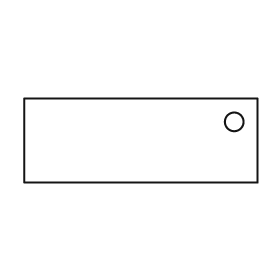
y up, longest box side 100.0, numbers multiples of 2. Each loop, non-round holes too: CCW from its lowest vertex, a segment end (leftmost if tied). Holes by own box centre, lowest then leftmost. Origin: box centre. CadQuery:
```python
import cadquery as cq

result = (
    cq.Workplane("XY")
    .moveTo(-50.0, -18.0)
    .lineTo(50.0, -18.0)
    .lineTo(50.0, 18.0)
    .lineTo(-50.0, 18.0)
    .close()
    .moveTo(40.0, 8.0)
    .circle(4.0)
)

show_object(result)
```